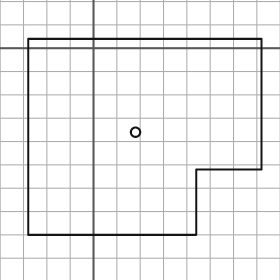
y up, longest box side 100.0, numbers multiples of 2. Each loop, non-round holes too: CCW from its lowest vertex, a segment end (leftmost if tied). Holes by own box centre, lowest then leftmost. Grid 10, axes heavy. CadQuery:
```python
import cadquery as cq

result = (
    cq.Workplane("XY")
    .moveTo(-28.0, -80.0)
    .lineTo(44.0, -80.0)
    .lineTo(44.0, -52.0)
    .lineTo(72.0, -52.0)
    .lineTo(72.0, 4.0)
    .lineTo(-28.0, 4.0)
    .close()
    .moveTo(18.0, -36.0)
    .circle(2.0)
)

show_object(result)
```